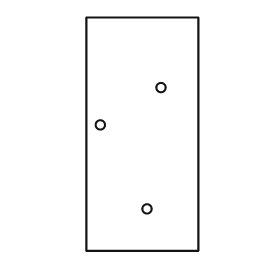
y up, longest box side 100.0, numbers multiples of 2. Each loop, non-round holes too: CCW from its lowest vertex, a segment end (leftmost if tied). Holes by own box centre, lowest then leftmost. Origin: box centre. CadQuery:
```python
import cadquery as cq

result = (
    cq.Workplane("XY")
    .moveTo(-24.0, -50.0)
    .lineTo(24.0, -50.0)
    .lineTo(24.0, 50.0)
    .lineTo(-24.0, 50.0)
    .close()
    .moveTo(2.0, -32.0)
    .circle(2.0)
    .moveTo(-18.0, 4.0)
    .circle(2.0)
    .moveTo(8.0, 20.0)
    .circle(2.0)
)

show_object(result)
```